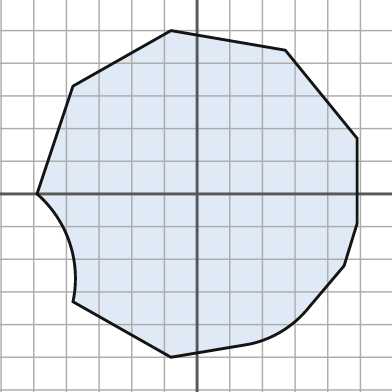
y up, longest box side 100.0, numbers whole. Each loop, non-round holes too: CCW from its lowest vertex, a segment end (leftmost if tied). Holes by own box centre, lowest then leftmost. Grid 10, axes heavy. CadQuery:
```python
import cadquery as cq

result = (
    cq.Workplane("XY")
    .moveTo(-8.0, -50.0)
    .lineTo(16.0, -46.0)
    .threePointArc((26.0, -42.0), (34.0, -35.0))
    .lineTo(45.0, -22.0)
    .lineTo(49.0, -9.0)
    .lineTo(49.0, 17.0)
    .lineTo(27.0, 44.0)
    .lineTo(-8.0, 50.0)
    .lineTo(-38.0, 33.0)
    .lineTo(-49.0, 0.0)
    .threePointArc((-39.0, -15.0), (-38.0, -33.0))
    .close()
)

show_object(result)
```